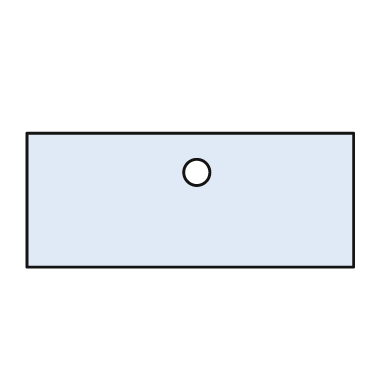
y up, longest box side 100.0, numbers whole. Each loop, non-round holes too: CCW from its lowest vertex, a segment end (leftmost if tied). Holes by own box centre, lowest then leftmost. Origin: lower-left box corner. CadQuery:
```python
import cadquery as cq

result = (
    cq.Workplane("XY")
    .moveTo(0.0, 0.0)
    .lineTo(100.0, 0.0)
    .lineTo(100.0, 41.0)
    .lineTo(0.0, 41.0)
    .close()
    .moveTo(52.0, 29.0)
    .circle(4.0)
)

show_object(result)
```